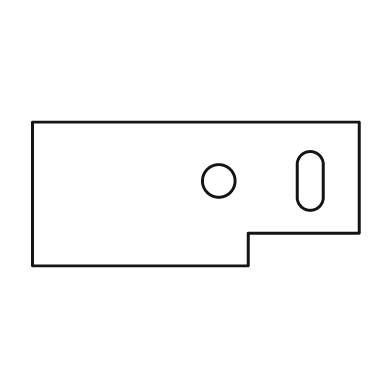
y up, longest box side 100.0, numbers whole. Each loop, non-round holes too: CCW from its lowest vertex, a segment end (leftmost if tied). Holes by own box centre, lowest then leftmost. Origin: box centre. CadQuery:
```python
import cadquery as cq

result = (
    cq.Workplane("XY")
    .moveTo(-50.0, -22.0)
    .lineTo(16.0, -22.0)
    .lineTo(16.0, -12.0)
    .lineTo(50.0, -12.0)
    .lineTo(50.0, 22.0)
    .lineTo(-50.0, 22.0)
    .close()
    .moveTo(7.0, 4.0)
    .circle(5.0)
    .moveTo(31.0, -1.0)
    .threePointArc((35.0, -5.0), (39.0, -1.0))
    .lineTo(39.0, 9.0)
    .threePointArc((35.0, 13.0), (31.0, 9.0))
    .close()
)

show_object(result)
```